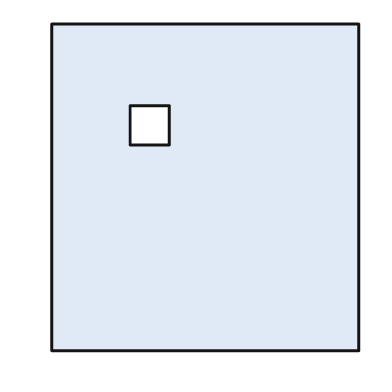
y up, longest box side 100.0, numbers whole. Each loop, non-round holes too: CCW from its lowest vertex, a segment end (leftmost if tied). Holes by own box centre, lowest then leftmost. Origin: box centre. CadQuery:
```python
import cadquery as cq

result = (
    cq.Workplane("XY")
    .moveTo(-47.0, -50.0)
    .lineTo(47.0, -50.0)
    .lineTo(47.0, 50.0)
    .lineTo(-47.0, 50.0)
    .close()
    .moveTo(-23.0, 13.0)
    .lineTo(-11.0, 13.0)
    .lineTo(-11.0, 25.0)
    .lineTo(-23.0, 25.0)
    .close()
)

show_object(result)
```